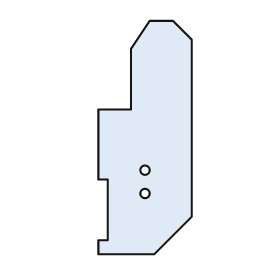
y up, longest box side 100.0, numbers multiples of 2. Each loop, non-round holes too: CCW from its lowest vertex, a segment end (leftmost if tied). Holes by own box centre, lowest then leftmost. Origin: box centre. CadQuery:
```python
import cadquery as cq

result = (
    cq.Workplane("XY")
    .moveTo(-20.0, -50.0)
    .lineTo(4.0, -50.0)
    .lineTo(20.0, -34.0)
    .lineTo(20.0, 42.0)
    .lineTo(12.0, 50.0)
    .lineTo(2.0, 50.0)
    .lineTo(-6.0, 38.0)
    .lineTo(-6.0, 12.0)
    .lineTo(-20.0, 12.0)
    .lineTo(-20.0, -18.0)
    .lineTo(-16.0, -18.0)
    .lineTo(-16.0, -44.0)
    .lineTo(-20.0, -44.0)
    .close()
    .moveTo(0.0, -24.0)
    .circle(2.0)
    .moveTo(0.0, -14.0)
    .circle(2.0)
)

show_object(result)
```